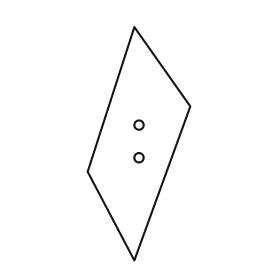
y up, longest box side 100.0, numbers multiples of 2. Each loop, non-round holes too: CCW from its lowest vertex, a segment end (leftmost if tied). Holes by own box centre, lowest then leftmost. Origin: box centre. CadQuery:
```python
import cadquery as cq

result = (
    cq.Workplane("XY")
    .moveTo(-2.0, -50.0)
    .lineTo(22.0, 16.0)
    .lineTo(-2.0, 50.0)
    .lineTo(-22.0, -12.0)
    .close()
    .moveTo(0.0, -6.0)
    .circle(2.0)
    .moveTo(0.0, 8.0)
    .circle(2.0)
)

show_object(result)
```